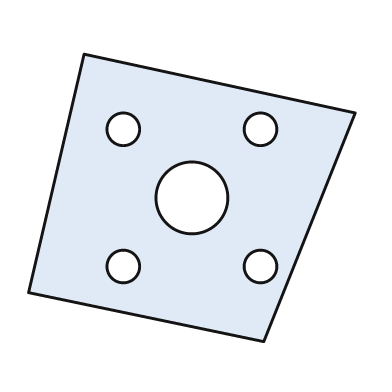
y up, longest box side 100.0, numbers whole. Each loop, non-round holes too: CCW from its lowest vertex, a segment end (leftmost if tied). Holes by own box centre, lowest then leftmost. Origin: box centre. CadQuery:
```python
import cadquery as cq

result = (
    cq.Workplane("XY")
    .moveTo(22.0, -44.0)
    .lineTo(50.0, 26.0)
    .lineTo(-33.0, 44.0)
    .lineTo(-50.0, -29.0)
    .close()
    .moveTo(-21.0, -21.0)
    .circle(5.0)
    .moveTo(21.0, -21.0)
    .circle(5.0)
    .moveTo(0.0, 0.0)
    .circle(11.0)
    .moveTo(-21.0, 21.0)
    .circle(5.0)
    .moveTo(21.0, 21.0)
    .circle(5.0)
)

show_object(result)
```